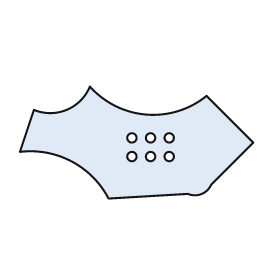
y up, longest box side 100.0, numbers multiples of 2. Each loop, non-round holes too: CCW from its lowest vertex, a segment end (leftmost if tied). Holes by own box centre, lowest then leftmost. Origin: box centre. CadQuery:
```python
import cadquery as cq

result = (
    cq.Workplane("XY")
    .moveTo(-12.0, -24.0)
    .lineTo(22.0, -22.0)
    .threePointArc((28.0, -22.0), (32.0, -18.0))
    .lineTo(50.0, 0.0)
    .lineTo(30.0, 20.0)
    .threePointArc((4.0, 12.0), (-20.0, 24.0))
    .threePointArc((-30.0, 14.0), (-44.0, 14.0))
    .lineTo(-50.0, -4.0)
    .threePointArc((-28.0, -8.0), (-12.0, -24.0))
    .close()
    .moveTo(-2.0, -6.0)
    .circle(2.0)
    .moveTo(6.0, -6.0)
    .circle(2.0)
    .moveTo(14.0, -6.0)
    .circle(2.0)
    .moveTo(-2.0, 2.0)
    .circle(2.0)
    .moveTo(6.0, 2.0)
    .circle(2.0)
    .moveTo(14.0, 2.0)
    .circle(2.0)
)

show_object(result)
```